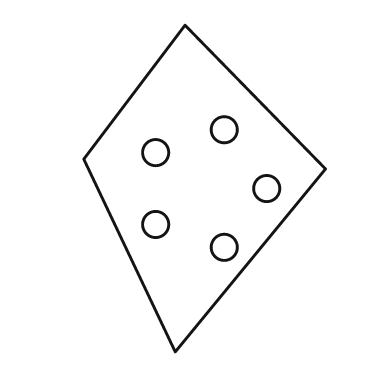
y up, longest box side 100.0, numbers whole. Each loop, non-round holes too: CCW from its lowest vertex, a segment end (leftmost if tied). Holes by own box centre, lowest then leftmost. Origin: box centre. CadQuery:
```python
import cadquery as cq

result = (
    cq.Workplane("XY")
    .moveTo(-9.0, -50.0)
    .lineTo(37.0, 6.0)
    .lineTo(-6.0, 50.0)
    .lineTo(-37.0, 9.0)
    .close()
    .moveTo(6.0, -18.0)
    .circle(4.0)
    .moveTo(-15.0, -11.0)
    .circle(4.0)
    .moveTo(19.0, 0.0)
    .circle(4.0)
    .moveTo(-15.0, 11.0)
    .circle(4.0)
    .moveTo(6.0, 18.0)
    .circle(4.0)
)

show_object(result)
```